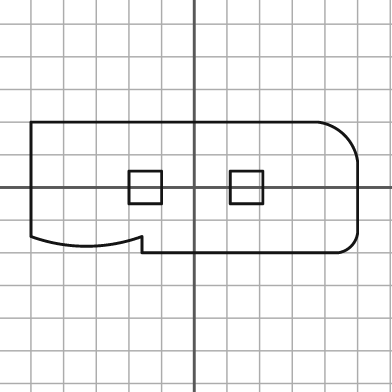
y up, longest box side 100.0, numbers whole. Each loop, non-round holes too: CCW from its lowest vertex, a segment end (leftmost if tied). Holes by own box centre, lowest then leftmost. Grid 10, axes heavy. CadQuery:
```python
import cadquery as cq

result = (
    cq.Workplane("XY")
    .moveTo(-16.0, -20.0)
    .lineTo(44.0, -20.0)
    .threePointArc((48.0, -18.0), (50.0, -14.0))
    .lineTo(50.0, 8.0)
    .threePointArc((46.0, 16.0), (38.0, 20.0))
    .lineTo(-50.0, 20.0)
    .lineTo(-50.0, -15.0)
    .threePointArc((-33.0, -18.0), (-16.0, -15.0))
    .close()
    .moveTo(-20.0, -5.0)
    .lineTo(-10.0, -5.0)
    .lineTo(-10.0, 5.0)
    .lineTo(-20.0, 5.0)
    .close()
    .moveTo(11.0, -5.0)
    .lineTo(21.0, -5.0)
    .lineTo(21.0, 5.0)
    .lineTo(11.0, 5.0)
    .close()
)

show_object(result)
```